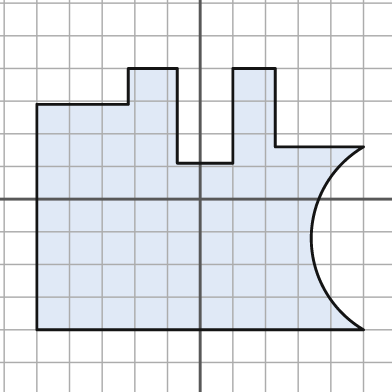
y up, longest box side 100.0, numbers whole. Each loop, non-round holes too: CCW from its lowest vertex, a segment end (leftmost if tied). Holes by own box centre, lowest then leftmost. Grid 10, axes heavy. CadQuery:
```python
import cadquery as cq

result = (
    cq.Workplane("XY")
    .moveTo(-50.0, -40.0)
    .lineTo(50.0, -40.0)
    .threePointArc((34.0, -12.0), (50.0, 16.0))
    .lineTo(23.0, 16.0)
    .lineTo(23.0, 40.0)
    .lineTo(10.0, 40.0)
    .lineTo(10.0, 11.0)
    .lineTo(-7.0, 11.0)
    .lineTo(-7.0, 40.0)
    .lineTo(-22.0, 40.0)
    .lineTo(-22.0, 29.0)
    .lineTo(-50.0, 29.0)
    .close()
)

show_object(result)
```